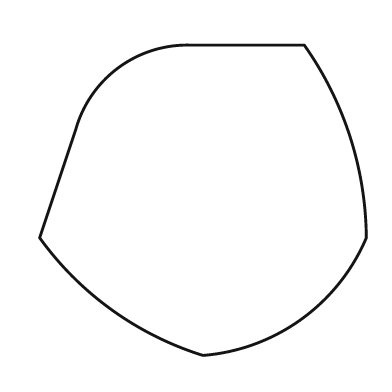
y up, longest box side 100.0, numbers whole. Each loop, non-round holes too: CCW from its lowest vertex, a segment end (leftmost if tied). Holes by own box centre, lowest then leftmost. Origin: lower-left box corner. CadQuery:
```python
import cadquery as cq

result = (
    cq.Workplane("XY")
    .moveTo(50.0, 0.0)
    .threePointArc((80.0, 11.0), (100.0, 36.0))
    .threePointArc((95.0, 67.0), (81.0, 95.0))
    .lineTo(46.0, 95.0)
    .threePointArc((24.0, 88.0), (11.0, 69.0))
    .lineTo(0.0, 36.0)
    .threePointArc((22.0, 14.0), (50.0, 0.0))
    .close()
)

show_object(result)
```